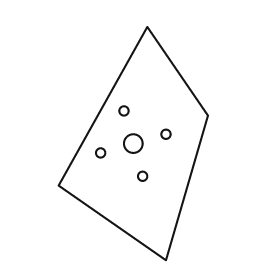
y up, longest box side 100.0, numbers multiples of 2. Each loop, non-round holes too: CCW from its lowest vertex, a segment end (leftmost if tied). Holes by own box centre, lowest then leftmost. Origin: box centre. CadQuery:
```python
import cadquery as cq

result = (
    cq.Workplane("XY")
    .moveTo(14.0, -50.0)
    .lineTo(32.0, 12.0)
    .lineTo(6.0, 50.0)
    .lineTo(-32.0, -18.0)
    .close()
    .moveTo(4.0, -14.0)
    .circle(2.0)
    .moveTo(-14.0, -4.0)
    .circle(2.0)
    .moveTo(0.0, 0.0)
    .circle(4.0)
    .moveTo(14.0, 4.0)
    .circle(2.0)
    .moveTo(-4.0, 14.0)
    .circle(2.0)
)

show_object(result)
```